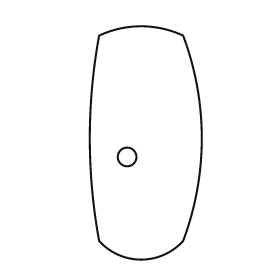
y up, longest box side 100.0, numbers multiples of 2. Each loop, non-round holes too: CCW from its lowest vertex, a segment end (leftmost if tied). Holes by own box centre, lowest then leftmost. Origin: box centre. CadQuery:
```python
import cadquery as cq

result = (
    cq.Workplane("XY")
    .moveTo(-20.0, -42.0)
    .threePointArc((-2.0, -50.0), (16.0, -42.0))
    .threePointArc((24.0, 2.0), (16.0, 46.0))
    .threePointArc((-2.0, 50.0), (-20.0, 46.0))
    .threePointArc((-24.0, 2.0), (-20.0, -42.0))
    .close()
    .moveTo(-8.0, -6.0)
    .circle(4.0)
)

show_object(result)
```